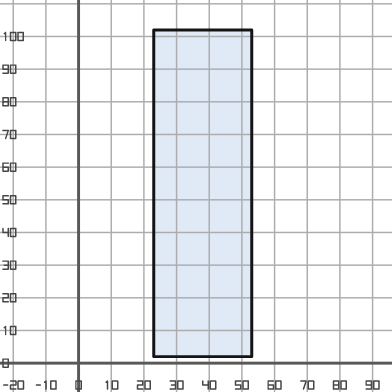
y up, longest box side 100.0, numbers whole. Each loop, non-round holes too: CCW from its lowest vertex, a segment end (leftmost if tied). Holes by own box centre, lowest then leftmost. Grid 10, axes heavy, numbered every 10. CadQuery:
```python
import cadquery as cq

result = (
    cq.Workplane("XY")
    .moveTo(23.0, 2.0)
    .lineTo(53.0, 2.0)
    .lineTo(53.0, 102.0)
    .lineTo(23.0, 102.0)
    .close()
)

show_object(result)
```